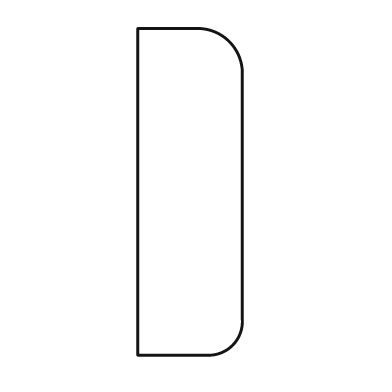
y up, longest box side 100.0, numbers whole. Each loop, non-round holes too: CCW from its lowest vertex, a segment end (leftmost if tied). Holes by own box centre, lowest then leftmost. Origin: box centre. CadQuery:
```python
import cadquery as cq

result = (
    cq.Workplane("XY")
    .moveTo(-16.0, -50.0)
    .lineTo(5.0, -50.0)
    .threePointArc((13.0, -47.0), (16.0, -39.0))
    .lineTo(16.0, 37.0)
    .threePointArc((12.0, 46.0), (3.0, 50.0))
    .lineTo(-16.0, 50.0)
    .close()
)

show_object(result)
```